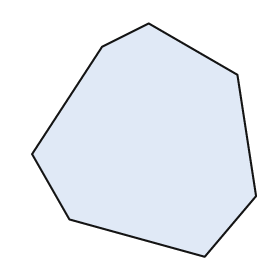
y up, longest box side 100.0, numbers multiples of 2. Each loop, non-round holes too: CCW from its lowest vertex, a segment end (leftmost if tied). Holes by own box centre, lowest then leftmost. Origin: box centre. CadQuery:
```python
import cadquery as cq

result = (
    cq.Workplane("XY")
    .moveTo(26.0, -50.0)
    .lineTo(48.0, -24.0)
    .lineTo(40.0, 28.0)
    .lineTo(2.0, 50.0)
    .lineTo(-18.0, 40.0)
    .lineTo(-48.0, -6.0)
    .lineTo(-32.0, -34.0)
    .close()
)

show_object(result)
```